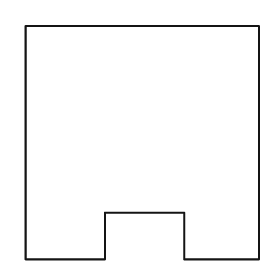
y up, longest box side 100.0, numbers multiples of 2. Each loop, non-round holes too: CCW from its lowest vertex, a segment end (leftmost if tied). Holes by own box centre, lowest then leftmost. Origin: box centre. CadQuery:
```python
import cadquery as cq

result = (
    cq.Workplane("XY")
    .moveTo(-50.0, -50.0)
    .lineTo(-16.0, -50.0)
    .lineTo(-16.0, -30.0)
    .lineTo(18.0, -30.0)
    .lineTo(18.0, -50.0)
    .lineTo(50.0, -50.0)
    .lineTo(50.0, 50.0)
    .lineTo(-50.0, 50.0)
    .close()
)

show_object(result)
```